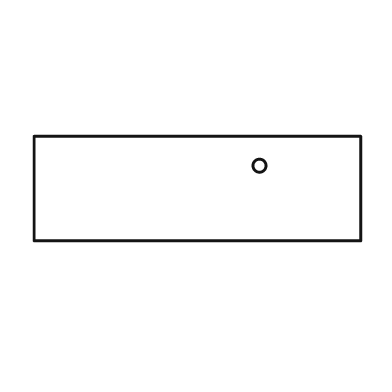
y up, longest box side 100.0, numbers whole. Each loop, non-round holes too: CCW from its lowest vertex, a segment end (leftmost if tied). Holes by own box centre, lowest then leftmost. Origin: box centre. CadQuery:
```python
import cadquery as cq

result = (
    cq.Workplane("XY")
    .moveTo(-50.0, -16.0)
    .lineTo(50.0, -16.0)
    .lineTo(50.0, 16.0)
    .lineTo(-50.0, 16.0)
    .close()
    .moveTo(19.0, 7.0)
    .circle(2.0)
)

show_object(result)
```